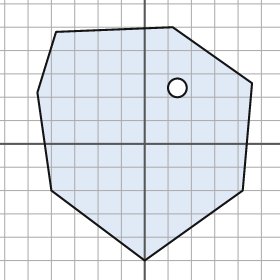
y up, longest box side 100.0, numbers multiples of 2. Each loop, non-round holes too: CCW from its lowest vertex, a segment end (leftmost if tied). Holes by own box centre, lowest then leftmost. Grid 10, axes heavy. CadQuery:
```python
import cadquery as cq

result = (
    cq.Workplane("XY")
    .moveTo(0.0, -50.0)
    .lineTo(42.0, -20.0)
    .lineTo(46.0, 26.0)
    .lineTo(12.0, 50.0)
    .lineTo(-38.0, 48.0)
    .lineTo(-46.0, 22.0)
    .lineTo(-40.0, -20.0)
    .close()
    .moveTo(14.0, 24.0)
    .circle(4.0)
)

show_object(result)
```